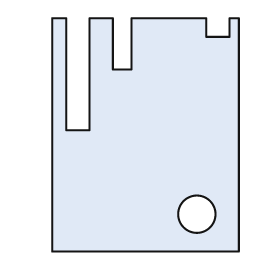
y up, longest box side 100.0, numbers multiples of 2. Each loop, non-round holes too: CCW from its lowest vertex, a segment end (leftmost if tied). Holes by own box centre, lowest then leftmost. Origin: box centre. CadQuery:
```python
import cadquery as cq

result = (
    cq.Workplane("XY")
    .moveTo(-40.0, -50.0)
    .lineTo(40.0, -50.0)
    .lineTo(40.0, 50.0)
    .lineTo(36.0, 50.0)
    .lineTo(36.0, 42.0)
    .lineTo(26.0, 42.0)
    .lineTo(26.0, 50.0)
    .lineTo(-6.0, 50.0)
    .lineTo(-6.0, 28.0)
    .lineTo(-14.0, 28.0)
    .lineTo(-14.0, 50.0)
    .lineTo(-24.0, 50.0)
    .lineTo(-24.0, 2.0)
    .lineTo(-34.0, 2.0)
    .lineTo(-34.0, 50.0)
    .lineTo(-40.0, 50.0)
    .close()
    .moveTo(22.0, -34.0)
    .circle(8.0)
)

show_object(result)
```